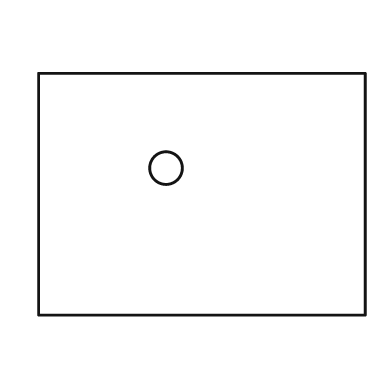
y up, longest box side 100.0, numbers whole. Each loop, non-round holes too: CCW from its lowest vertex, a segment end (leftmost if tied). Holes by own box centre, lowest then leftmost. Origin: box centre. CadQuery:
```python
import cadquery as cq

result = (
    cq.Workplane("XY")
    .moveTo(-50.0, -37.0)
    .lineTo(50.0, -37.0)
    .lineTo(50.0, 37.0)
    .lineTo(-50.0, 37.0)
    .close()
    .moveTo(-11.0, 8.0)
    .circle(5.0)
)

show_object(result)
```